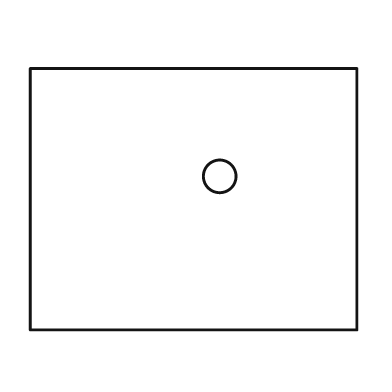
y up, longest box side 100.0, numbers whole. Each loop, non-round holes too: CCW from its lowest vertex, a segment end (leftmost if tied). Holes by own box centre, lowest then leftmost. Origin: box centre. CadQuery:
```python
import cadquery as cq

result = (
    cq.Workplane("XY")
    .moveTo(-50.0, -40.0)
    .lineTo(50.0, -40.0)
    .lineTo(50.0, 40.0)
    .lineTo(-50.0, 40.0)
    .close()
    .moveTo(8.0, 7.0)
    .circle(5.0)
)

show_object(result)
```